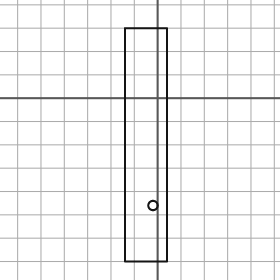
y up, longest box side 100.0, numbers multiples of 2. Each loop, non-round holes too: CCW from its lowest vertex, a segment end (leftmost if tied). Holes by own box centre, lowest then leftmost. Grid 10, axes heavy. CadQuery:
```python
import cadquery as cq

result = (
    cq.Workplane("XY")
    .moveTo(-14.0, -70.0)
    .lineTo(4.0, -70.0)
    .lineTo(4.0, 30.0)
    .lineTo(-14.0, 30.0)
    .close()
    .moveTo(-2.0, -46.0)
    .circle(2.0)
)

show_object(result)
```